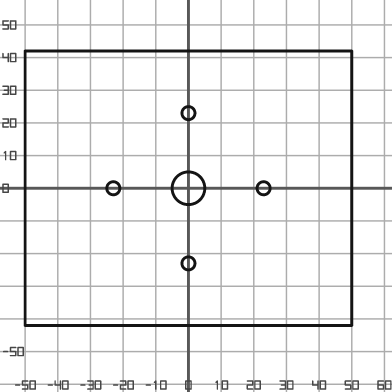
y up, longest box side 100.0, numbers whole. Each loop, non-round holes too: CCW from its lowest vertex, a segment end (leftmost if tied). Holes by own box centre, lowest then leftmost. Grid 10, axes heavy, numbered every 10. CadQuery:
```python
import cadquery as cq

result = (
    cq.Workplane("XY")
    .moveTo(-50.0, -42.0)
    .lineTo(50.0, -42.0)
    .lineTo(50.0, 42.0)
    .lineTo(-50.0, 42.0)
    .close()
    .moveTo(0.0, -23.0)
    .circle(2.0)
    .moveTo(-23.0, 0.0)
    .circle(2.0)
    .moveTo(0.0, 0.0)
    .circle(5.0)
    .moveTo(23.0, 0.0)
    .circle(2.0)
    .moveTo(0.0, 23.0)
    .circle(2.0)
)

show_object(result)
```